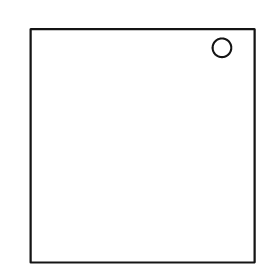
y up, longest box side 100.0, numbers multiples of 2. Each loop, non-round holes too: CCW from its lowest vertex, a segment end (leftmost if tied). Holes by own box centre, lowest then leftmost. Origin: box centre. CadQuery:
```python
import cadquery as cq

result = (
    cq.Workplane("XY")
    .moveTo(-48.0, -50.0)
    .lineTo(48.0, -50.0)
    .lineTo(48.0, 50.0)
    .lineTo(-48.0, 50.0)
    .close()
    .moveTo(34.0, 42.0)
    .circle(4.0)
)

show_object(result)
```